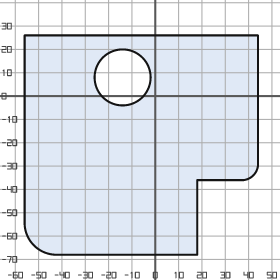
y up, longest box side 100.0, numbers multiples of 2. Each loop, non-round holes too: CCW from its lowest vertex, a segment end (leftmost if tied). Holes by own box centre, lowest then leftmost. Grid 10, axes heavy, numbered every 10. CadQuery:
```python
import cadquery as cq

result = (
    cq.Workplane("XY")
    .moveTo(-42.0, -68.0)
    .lineTo(18.0, -68.0)
    .lineTo(18.0, -36.0)
    .lineTo(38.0, -36.0)
    .threePointArc((42.0, -34.0), (44.0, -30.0))
    .lineTo(44.0, 26.0)
    .lineTo(-56.0, 26.0)
    .lineTo(-56.0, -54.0)
    .threePointArc((-52.0, -64.0), (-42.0, -68.0))
    .close()
    .moveTo(-14.0, 8.0)
    .circle(12.0)
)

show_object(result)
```